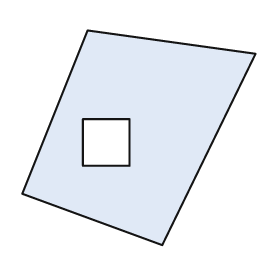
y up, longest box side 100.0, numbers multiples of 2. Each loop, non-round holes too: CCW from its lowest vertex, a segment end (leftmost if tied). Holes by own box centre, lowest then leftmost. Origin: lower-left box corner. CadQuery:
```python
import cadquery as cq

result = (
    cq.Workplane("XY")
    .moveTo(60.0, 0.0)
    .lineTo(100.0, 82.0)
    .lineTo(28.0, 92.0)
    .lineTo(0.0, 22.0)
    .close()
    .moveTo(26.0, 34.0)
    .lineTo(46.0, 34.0)
    .lineTo(46.0, 54.0)
    .lineTo(26.0, 54.0)
    .close()
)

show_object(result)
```